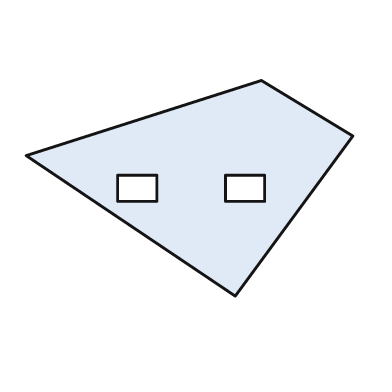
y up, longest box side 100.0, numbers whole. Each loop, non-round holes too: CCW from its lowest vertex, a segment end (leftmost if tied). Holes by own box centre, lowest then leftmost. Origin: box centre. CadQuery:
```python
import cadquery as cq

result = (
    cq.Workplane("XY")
    .moveTo(14.0, -33.0)
    .lineTo(50.0, 16.0)
    .lineTo(22.0, 33.0)
    .lineTo(-50.0, 10.0)
    .close()
    .moveTo(-22.0, -4.0)
    .lineTo(-10.0, -4.0)
    .lineTo(-10.0, 4.0)
    .lineTo(-22.0, 4.0)
    .close()
    .moveTo(11.0, -4.0)
    .lineTo(23.0, -4.0)
    .lineTo(23.0, 4.0)
    .lineTo(11.0, 4.0)
    .close()
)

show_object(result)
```